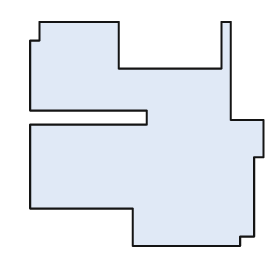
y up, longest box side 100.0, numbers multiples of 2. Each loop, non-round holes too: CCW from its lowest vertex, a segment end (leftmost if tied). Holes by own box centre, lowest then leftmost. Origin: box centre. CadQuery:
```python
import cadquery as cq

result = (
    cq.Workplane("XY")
    .moveTo(-6.0, -48.0)
    .lineTo(40.0, -48.0)
    .lineTo(40.0, -44.0)
    .lineTo(46.0, -44.0)
    .lineTo(46.0, -10.0)
    .lineTo(50.0, -10.0)
    .lineTo(50.0, 6.0)
    .lineTo(36.0, 6.0)
    .lineTo(36.0, 48.0)
    .lineTo(32.0, 48.0)
    .lineTo(32.0, 28.0)
    .lineTo(-12.0, 28.0)
    .lineTo(-12.0, 48.0)
    .lineTo(-46.0, 48.0)
    .lineTo(-46.0, 40.0)
    .lineTo(-50.0, 40.0)
    .lineTo(-50.0, 10.0)
    .lineTo(0.0, 10.0)
    .lineTo(0.0, 4.0)
    .lineTo(-50.0, 4.0)
    .lineTo(-50.0, -32.0)
    .lineTo(-6.0, -32.0)
    .close()
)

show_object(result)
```